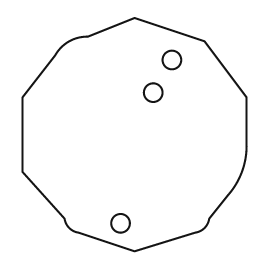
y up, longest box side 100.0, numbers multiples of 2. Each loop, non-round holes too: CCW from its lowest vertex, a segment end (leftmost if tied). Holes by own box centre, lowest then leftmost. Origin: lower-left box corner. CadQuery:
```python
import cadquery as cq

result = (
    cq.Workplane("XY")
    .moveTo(48.0, 0.0)
    .lineTo(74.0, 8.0)
    .threePointArc((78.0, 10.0), (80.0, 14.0))
    .lineTo(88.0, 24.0)
    .threePointArc((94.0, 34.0), (96.0, 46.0))
    .lineTo(96.0, 66.0)
    .lineTo(78.0, 90.0)
    .lineTo(48.0, 100.0)
    .lineTo(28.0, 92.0)
    .threePointArc((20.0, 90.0), (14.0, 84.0))
    .lineTo(0.0, 66.0)
    .lineTo(0.0, 34.0)
    .lineTo(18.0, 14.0)
    .threePointArc((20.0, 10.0), (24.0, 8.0))
    .close()
    .moveTo(42.0, 12.0)
    .circle(4.0)
    .moveTo(56.0, 68.0)
    .circle(4.0)
    .moveTo(64.0, 82.0)
    .circle(4.0)
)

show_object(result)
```